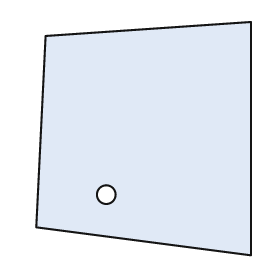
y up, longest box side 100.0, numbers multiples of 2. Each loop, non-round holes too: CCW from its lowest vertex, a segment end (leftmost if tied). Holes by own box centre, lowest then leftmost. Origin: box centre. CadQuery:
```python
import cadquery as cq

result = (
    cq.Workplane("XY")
    .moveTo(46.0, -50.0)
    .lineTo(46.0, 50.0)
    .lineTo(-42.0, 44.0)
    .lineTo(-46.0, -38.0)
    .close()
    .moveTo(-16.0, -24.0)
    .circle(4.0)
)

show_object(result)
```